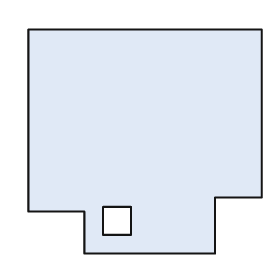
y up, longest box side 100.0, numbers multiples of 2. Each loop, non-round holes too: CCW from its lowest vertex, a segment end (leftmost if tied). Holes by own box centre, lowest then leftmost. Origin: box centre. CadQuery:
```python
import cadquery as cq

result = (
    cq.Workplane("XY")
    .moveTo(-26.0, -48.0)
    .lineTo(30.0, -48.0)
    .lineTo(30.0, -24.0)
    .lineTo(50.0, -24.0)
    .lineTo(50.0, 48.0)
    .lineTo(-50.0, 48.0)
    .lineTo(-50.0, -30.0)
    .lineTo(-26.0, -30.0)
    .close()
    .moveTo(-18.0, -40.0)
    .lineTo(-6.0, -40.0)
    .lineTo(-6.0, -28.0)
    .lineTo(-18.0, -28.0)
    .close()
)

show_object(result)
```